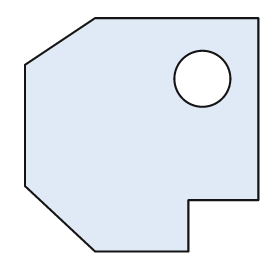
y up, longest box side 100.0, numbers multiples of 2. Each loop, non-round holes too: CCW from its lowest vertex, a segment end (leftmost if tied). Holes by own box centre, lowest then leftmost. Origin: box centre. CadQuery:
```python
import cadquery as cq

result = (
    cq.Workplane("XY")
    .moveTo(-20.0, -50.0)
    .lineTo(20.0, -50.0)
    .lineTo(20.0, -28.0)
    .lineTo(50.0, -28.0)
    .lineTo(50.0, 50.0)
    .lineTo(-20.0, 50.0)
    .lineTo(-50.0, 30.0)
    .lineTo(-50.0, -22.0)
    .close()
    .moveTo(26.0, 24.0)
    .circle(12.0)
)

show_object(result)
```